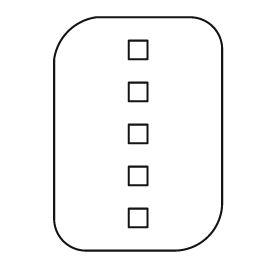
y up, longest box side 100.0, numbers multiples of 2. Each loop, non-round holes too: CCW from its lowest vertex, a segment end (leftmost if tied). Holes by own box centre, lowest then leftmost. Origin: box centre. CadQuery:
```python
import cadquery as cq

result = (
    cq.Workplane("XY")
    .moveTo(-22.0, -50.0)
    .lineTo(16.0, -50.0)
    .threePointArc((30.0, -44.0), (36.0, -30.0))
    .lineTo(36.0, 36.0)
    .threePointArc((32.0, 46.0), (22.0, 50.0))
    .lineTo(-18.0, 50.0)
    .threePointArc((-30.0, 44.0), (-36.0, 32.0))
    .lineTo(-36.0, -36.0)
    .threePointArc((-32.0, -46.0), (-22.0, -50.0))
    .close()
    .moveTo(-4.0, -40.0)
    .lineTo(4.0, -40.0)
    .lineTo(4.0, -32.0)
    .lineTo(-4.0, -32.0)
    .close()
    .moveTo(-4.0, -22.0)
    .lineTo(4.0, -22.0)
    .lineTo(4.0, -14.0)
    .lineTo(-4.0, -14.0)
    .close()
    .moveTo(-4.0, -4.0)
    .lineTo(4.0, -4.0)
    .lineTo(4.0, 4.0)
    .lineTo(-4.0, 4.0)
    .close()
    .moveTo(-4.0, 14.0)
    .lineTo(4.0, 14.0)
    .lineTo(4.0, 22.0)
    .lineTo(-4.0, 22.0)
    .close()
    .moveTo(-4.0, 32.0)
    .lineTo(4.0, 32.0)
    .lineTo(4.0, 40.0)
    .lineTo(-4.0, 40.0)
    .close()
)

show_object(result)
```